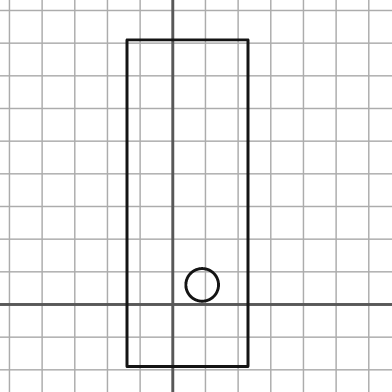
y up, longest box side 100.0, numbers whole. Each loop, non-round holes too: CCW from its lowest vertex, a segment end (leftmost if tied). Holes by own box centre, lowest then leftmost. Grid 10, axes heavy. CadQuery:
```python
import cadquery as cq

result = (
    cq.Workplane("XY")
    .moveTo(-14.0, -19.0)
    .lineTo(23.0, -19.0)
    .lineTo(23.0, 81.0)
    .lineTo(-14.0, 81.0)
    .close()
    .moveTo(9.0, 6.0)
    .circle(5.0)
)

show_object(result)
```